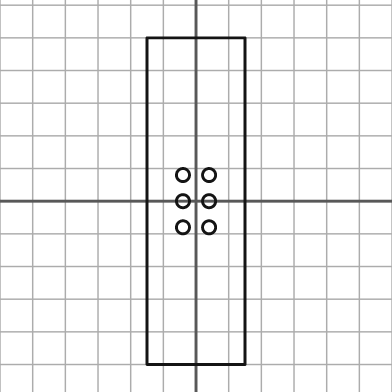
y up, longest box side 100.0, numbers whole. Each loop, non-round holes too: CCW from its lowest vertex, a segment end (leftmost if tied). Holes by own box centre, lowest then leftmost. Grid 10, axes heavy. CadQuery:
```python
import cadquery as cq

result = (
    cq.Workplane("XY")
    .moveTo(-15.0, -50.0)
    .lineTo(15.0, -50.0)
    .lineTo(15.0, 50.0)
    .lineTo(-15.0, 50.0)
    .close()
    .moveTo(-4.0, -8.0)
    .circle(2.0)
    .moveTo(4.0, -8.0)
    .circle(2.0)
    .moveTo(-4.0, 0.0)
    .circle(2.0)
    .moveTo(4.0, 0.0)
    .circle(2.0)
    .moveTo(-4.0, 8.0)
    .circle(2.0)
    .moveTo(4.0, 8.0)
    .circle(2.0)
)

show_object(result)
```